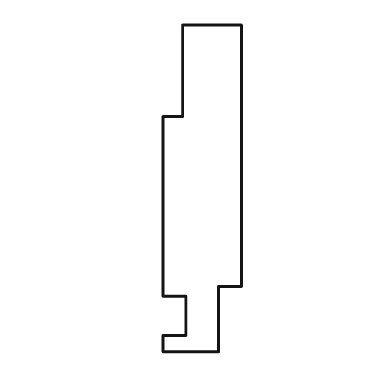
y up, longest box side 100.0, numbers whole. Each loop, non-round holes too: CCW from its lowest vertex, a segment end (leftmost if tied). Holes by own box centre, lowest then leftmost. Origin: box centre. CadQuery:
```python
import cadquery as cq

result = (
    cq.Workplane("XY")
    .moveTo(-12.0, -50.0)
    .lineTo(5.0, -50.0)
    .lineTo(5.0, -30.0)
    .lineTo(12.0, -30.0)
    .lineTo(12.0, 50.0)
    .lineTo(-6.0, 50.0)
    .lineTo(-6.0, 22.0)
    .lineTo(-12.0, 22.0)
    .lineTo(-12.0, -33.0)
    .lineTo(-5.0, -33.0)
    .lineTo(-5.0, -45.0)
    .lineTo(-12.0, -45.0)
    .close()
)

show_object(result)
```